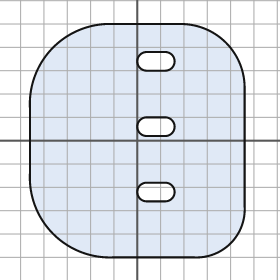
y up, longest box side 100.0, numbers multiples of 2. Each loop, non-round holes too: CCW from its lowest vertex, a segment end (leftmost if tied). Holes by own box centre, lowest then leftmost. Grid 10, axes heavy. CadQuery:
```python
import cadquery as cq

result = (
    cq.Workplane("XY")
    .moveTo(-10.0, -50.0)
    .lineTo(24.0, -50.0)
    .threePointArc((40.0, -44.0), (46.0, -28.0))
    .lineTo(46.0, 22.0)
    .threePointArc((38.0, 42.0), (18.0, 50.0))
    .lineTo(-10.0, 50.0)
    .threePointArc((-36.0, 40.0), (-46.0, 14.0))
    .lineTo(-46.0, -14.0)
    .threePointArc((-36.0, -40.0), (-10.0, -50.0))
    .close()
    .moveTo(4.0, -26.0)
    .lineTo(12.0, -26.0)
    .threePointArc((16.0, -22.0), (12.0, -18.0))
    .lineTo(4.0, -18.0)
    .threePointArc((0.0, -22.0), (4.0, -26.0))
    .close()
    .moveTo(4.0, 2.0)
    .lineTo(12.0, 2.0)
    .threePointArc((16.0, 6.0), (12.0, 10.0))
    .lineTo(4.0, 10.0)
    .threePointArc((0.0, 6.0), (4.0, 2.0))
    .close()
    .moveTo(4.0, 30.0)
    .lineTo(12.0, 30.0)
    .threePointArc((16.0, 34.0), (12.0, 38.0))
    .lineTo(4.0, 38.0)
    .threePointArc((0.0, 34.0), (4.0, 30.0))
    .close()
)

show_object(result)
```